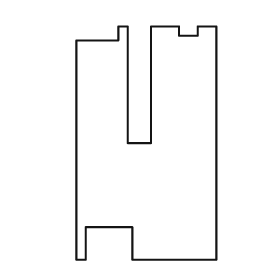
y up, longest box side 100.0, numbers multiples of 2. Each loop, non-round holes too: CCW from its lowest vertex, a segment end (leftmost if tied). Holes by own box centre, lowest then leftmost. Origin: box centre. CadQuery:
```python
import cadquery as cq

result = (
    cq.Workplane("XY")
    .moveTo(-30.0, -50.0)
    .lineTo(-26.0, -50.0)
    .lineTo(-26.0, -36.0)
    .lineTo(-6.0, -36.0)
    .lineTo(-6.0, -50.0)
    .lineTo(30.0, -50.0)
    .lineTo(30.0, 50.0)
    .lineTo(22.0, 50.0)
    .lineTo(22.0, 46.0)
    .lineTo(14.0, 46.0)
    .lineTo(14.0, 50.0)
    .lineTo(2.0, 50.0)
    .lineTo(2.0, 0.0)
    .lineTo(-8.0, 0.0)
    .lineTo(-8.0, 50.0)
    .lineTo(-12.0, 50.0)
    .lineTo(-12.0, 44.0)
    .lineTo(-30.0, 44.0)
    .close()
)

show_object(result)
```